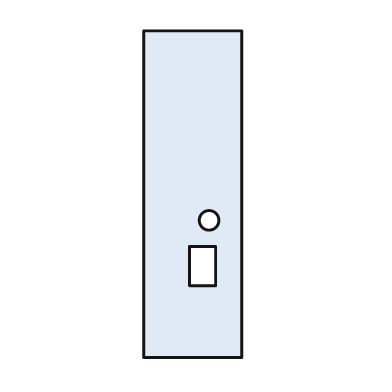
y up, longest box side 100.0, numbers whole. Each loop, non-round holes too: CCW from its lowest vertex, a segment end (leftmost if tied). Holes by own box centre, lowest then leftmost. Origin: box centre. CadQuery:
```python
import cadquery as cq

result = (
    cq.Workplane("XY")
    .moveTo(-15.0, -50.0)
    .lineTo(15.0, -50.0)
    .lineTo(15.0, 50.0)
    .lineTo(-15.0, 50.0)
    .close()
    .moveTo(-1.0, -28.0)
    .lineTo(7.0, -28.0)
    .lineTo(7.0, -16.0)
    .lineTo(-1.0, -16.0)
    .close()
    .moveTo(5.0, -8.0)
    .circle(3.0)
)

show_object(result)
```